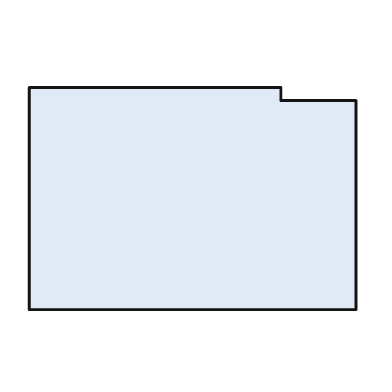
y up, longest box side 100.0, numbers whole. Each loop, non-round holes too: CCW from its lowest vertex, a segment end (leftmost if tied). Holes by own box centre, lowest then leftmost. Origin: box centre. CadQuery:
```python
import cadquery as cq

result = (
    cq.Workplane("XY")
    .moveTo(-50.0, -34.0)
    .lineTo(50.0, -34.0)
    .lineTo(50.0, 30.0)
    .lineTo(27.0, 30.0)
    .lineTo(27.0, 34.0)
    .lineTo(-50.0, 34.0)
    .close()
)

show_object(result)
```